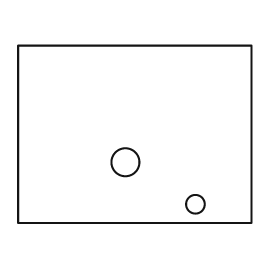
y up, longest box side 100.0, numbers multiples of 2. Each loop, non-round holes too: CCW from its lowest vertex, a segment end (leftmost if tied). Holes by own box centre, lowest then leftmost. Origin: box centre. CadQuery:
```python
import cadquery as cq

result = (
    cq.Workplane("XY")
    .moveTo(-50.0, -38.0)
    .lineTo(50.0, -38.0)
    .lineTo(50.0, 38.0)
    .lineTo(-50.0, 38.0)
    .close()
    .moveTo(26.0, -30.0)
    .circle(4.0)
    .moveTo(-4.0, -12.0)
    .circle(6.0)
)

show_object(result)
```